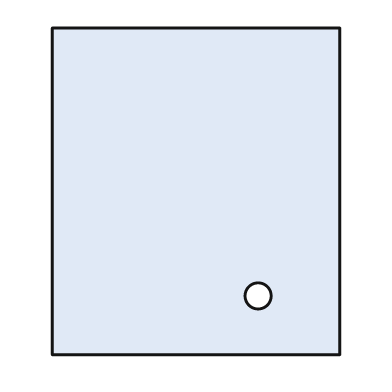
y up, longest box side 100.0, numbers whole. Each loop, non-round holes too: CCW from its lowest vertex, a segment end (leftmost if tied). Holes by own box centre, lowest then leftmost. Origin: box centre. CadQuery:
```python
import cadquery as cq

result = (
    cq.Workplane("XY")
    .moveTo(-44.0, -50.0)
    .lineTo(44.0, -50.0)
    .lineTo(44.0, 50.0)
    .lineTo(-44.0, 50.0)
    .close()
    .moveTo(19.0, -32.0)
    .circle(4.0)
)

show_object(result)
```